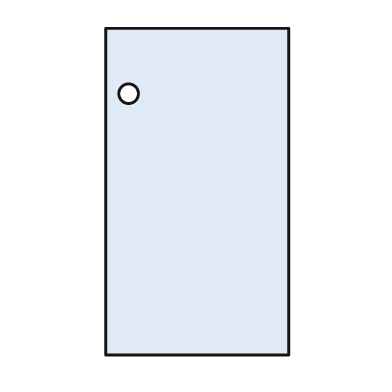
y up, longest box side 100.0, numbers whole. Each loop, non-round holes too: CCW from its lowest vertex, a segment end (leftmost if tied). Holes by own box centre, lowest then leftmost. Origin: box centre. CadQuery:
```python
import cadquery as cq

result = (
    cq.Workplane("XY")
    .moveTo(-28.0, -50.0)
    .lineTo(28.0, -50.0)
    .lineTo(28.0, 50.0)
    .lineTo(-28.0, 50.0)
    .close()
    .moveTo(-21.0, 30.0)
    .circle(3.0)
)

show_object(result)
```